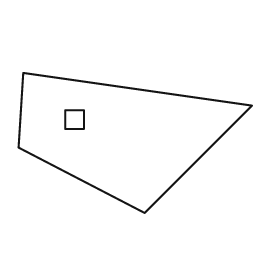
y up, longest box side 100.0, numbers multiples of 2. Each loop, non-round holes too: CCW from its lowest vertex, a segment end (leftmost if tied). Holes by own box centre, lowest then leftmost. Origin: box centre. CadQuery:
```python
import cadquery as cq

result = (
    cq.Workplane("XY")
    .moveTo(4.0, -30.0)
    .lineTo(50.0, 16.0)
    .lineTo(-48.0, 30.0)
    .lineTo(-50.0, -2.0)
    .close()
    .moveTo(-30.0, 6.0)
    .lineTo(-22.0, 6.0)
    .lineTo(-22.0, 14.0)
    .lineTo(-30.0, 14.0)
    .close()
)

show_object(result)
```